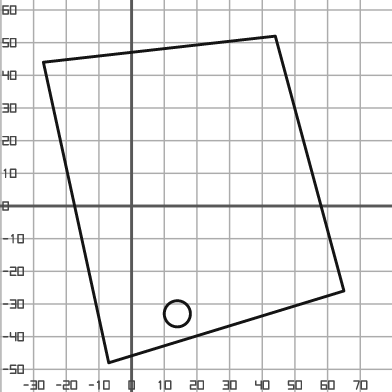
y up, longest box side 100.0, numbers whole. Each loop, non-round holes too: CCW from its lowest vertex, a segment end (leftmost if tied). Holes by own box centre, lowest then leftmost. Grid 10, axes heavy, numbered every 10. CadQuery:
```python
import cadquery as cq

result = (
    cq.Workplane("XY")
    .moveTo(-7.0, -48.0)
    .lineTo(65.0, -26.0)
    .lineTo(44.0, 52.0)
    .lineTo(-27.0, 44.0)
    .close()
    .moveTo(14.0, -33.0)
    .circle(4.0)
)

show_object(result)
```